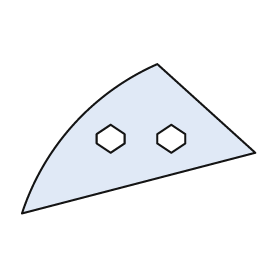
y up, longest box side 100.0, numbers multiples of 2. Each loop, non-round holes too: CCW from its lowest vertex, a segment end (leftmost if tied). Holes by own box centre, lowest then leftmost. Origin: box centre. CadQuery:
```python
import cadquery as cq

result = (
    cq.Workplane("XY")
    .moveTo(-50.0, -32.0)
    .lineTo(50.0, -6.0)
    .lineTo(8.0, 32.0)
    .threePointArc((-28.0, 6.0), (-50.0, -32.0))
    .close()
    .moveTo(-12.0, -6.0)
    .lineTo(-6.0, -2.0)
    .lineTo(-6.0, 2.0)
    .lineTo(-12.0, 6.0)
    .lineTo(-18.0, 2.0)
    .lineTo(-18.0, -2.0)
    .close()
    .moveTo(14.0, -6.0)
    .lineTo(20.0, -2.0)
    .lineTo(20.0, 2.0)
    .lineTo(14.0, 6.0)
    .lineTo(8.0, 2.0)
    .lineTo(8.0, -2.0)
    .close()
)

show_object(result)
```